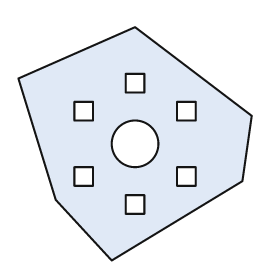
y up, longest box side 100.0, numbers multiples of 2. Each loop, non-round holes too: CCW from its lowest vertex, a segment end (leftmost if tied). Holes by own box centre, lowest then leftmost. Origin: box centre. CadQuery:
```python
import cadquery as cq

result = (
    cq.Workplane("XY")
    .moveTo(-10.0, -50.0)
    .lineTo(46.0, -16.0)
    .lineTo(50.0, 12.0)
    .lineTo(0.0, 50.0)
    .lineTo(-50.0, 28.0)
    .lineTo(-34.0, -24.0)
    .close()
    .moveTo(-4.0, -30.0)
    .lineTo(4.0, -30.0)
    .lineTo(4.0, -22.0)
    .lineTo(-4.0, -22.0)
    .close()
    .moveTo(-26.0, -18.0)
    .lineTo(-18.0, -18.0)
    .lineTo(-18.0, -10.0)
    .lineTo(-26.0, -10.0)
    .close()
    .moveTo(18.0, -18.0)
    .lineTo(26.0, -18.0)
    .lineTo(26.0, -10.0)
    .lineTo(18.0, -10.0)
    .close()
    .moveTo(0.0, 0.0)
    .circle(10.0)
    .moveTo(-26.0, 10.0)
    .lineTo(-18.0, 10.0)
    .lineTo(-18.0, 18.0)
    .lineTo(-26.0, 18.0)
    .close()
    .moveTo(18.0, 10.0)
    .lineTo(26.0, 10.0)
    .lineTo(26.0, 18.0)
    .lineTo(18.0, 18.0)
    .close()
    .moveTo(-4.0, 22.0)
    .lineTo(4.0, 22.0)
    .lineTo(4.0, 30.0)
    .lineTo(-4.0, 30.0)
    .close()
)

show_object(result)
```